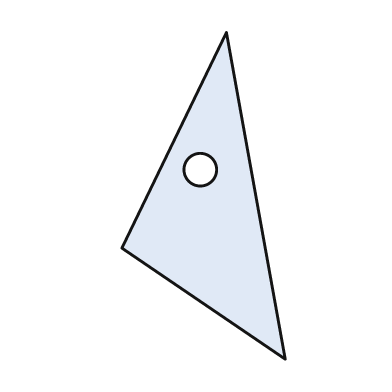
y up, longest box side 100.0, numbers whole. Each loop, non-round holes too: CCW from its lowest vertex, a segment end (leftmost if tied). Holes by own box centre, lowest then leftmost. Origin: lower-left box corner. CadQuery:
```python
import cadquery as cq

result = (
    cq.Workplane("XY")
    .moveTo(50.0, 0.0)
    .lineTo(32.0, 100.0)
    .lineTo(0.0, 34.0)
    .close()
    .moveTo(24.0, 58.0)
    .circle(5.0)
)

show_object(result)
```